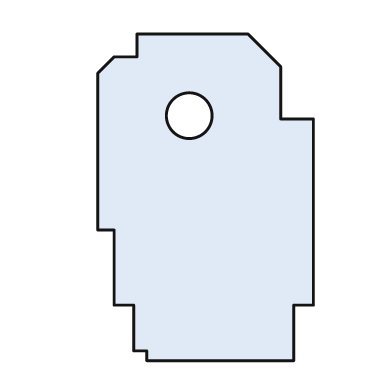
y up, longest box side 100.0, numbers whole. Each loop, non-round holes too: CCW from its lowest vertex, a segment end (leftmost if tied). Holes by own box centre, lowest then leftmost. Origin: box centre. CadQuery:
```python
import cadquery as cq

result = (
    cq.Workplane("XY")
    .moveTo(-18.0, -50.0)
    .lineTo(27.0, -50.0)
    .lineTo(27.0, -33.0)
    .lineTo(33.0, -33.0)
    .lineTo(33.0, 24.0)
    .lineTo(23.0, 24.0)
    .lineTo(23.0, 40.0)
    .lineTo(13.0, 50.0)
    .lineTo(-21.0, 50.0)
    .lineTo(-21.0, 43.0)
    .lineTo(-28.0, 43.0)
    .lineTo(-33.0, 38.0)
    .lineTo(-33.0, -10.0)
    .lineTo(-28.0, -10.0)
    .lineTo(-28.0, -33.0)
    .lineTo(-22.0, -33.0)
    .lineTo(-22.0, -47.0)
    .lineTo(-18.0, -47.0)
    .close()
    .moveTo(-5.0, 25.0)
    .circle(7.0)
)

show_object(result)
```